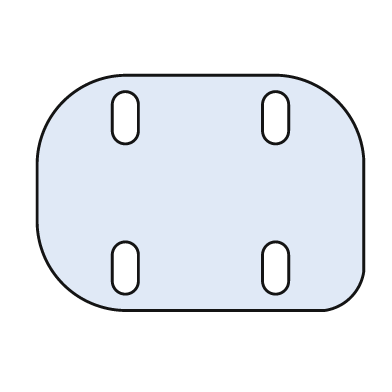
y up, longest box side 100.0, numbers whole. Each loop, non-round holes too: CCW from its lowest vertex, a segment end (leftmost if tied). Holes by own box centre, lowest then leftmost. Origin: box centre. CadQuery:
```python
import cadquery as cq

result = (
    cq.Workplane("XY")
    .moveTo(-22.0, -36.0)
    .lineTo(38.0, -36.0)
    .threePointArc((46.0, -32.0), (50.0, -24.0))
    .lineTo(50.0, 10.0)
    .threePointArc((42.0, 28.0), (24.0, 36.0))
    .lineTo(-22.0, 36.0)
    .threePointArc((-42.0, 28.0), (-50.0, 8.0))
    .lineTo(-50.0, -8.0)
    .threePointArc((-42.0, -28.0), (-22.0, -36.0))
    .close()
    .moveTo(-27.0, -27.0)
    .threePointArc((-23.0, -31.0), (-19.0, -27.0))
    .lineTo(-19.0, -19.0)
    .threePointArc((-23.0, -15.0), (-27.0, -19.0))
    .close()
    .moveTo(19.0, -27.0)
    .threePointArc((23.0, -31.0), (27.0, -27.0))
    .lineTo(27.0, -19.0)
    .threePointArc((23.0, -15.0), (19.0, -19.0))
    .close()
    .moveTo(-27.0, 19.0)
    .threePointArc((-23.0, 15.0), (-19.0, 19.0))
    .lineTo(-19.0, 27.0)
    .threePointArc((-23.0, 31.0), (-27.0, 27.0))
    .close()
    .moveTo(19.0, 19.0)
    .threePointArc((23.0, 15.0), (27.0, 19.0))
    .lineTo(27.0, 27.0)
    .threePointArc((23.0, 31.0), (19.0, 27.0))
    .close()
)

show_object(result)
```